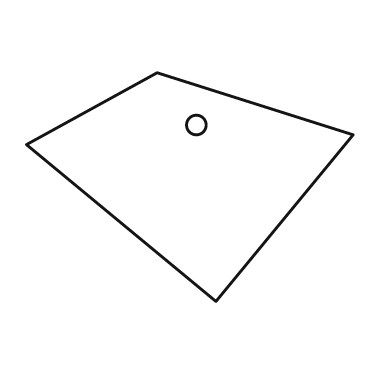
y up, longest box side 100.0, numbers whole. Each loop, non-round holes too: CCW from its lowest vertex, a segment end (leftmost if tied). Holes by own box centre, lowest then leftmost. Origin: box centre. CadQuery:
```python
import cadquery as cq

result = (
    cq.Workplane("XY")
    .moveTo(8.0, -35.0)
    .lineTo(50.0, 16.0)
    .lineTo(-10.0, 35.0)
    .lineTo(-50.0, 13.0)
    .close()
    .moveTo(2.0, 19.0)
    .circle(3.0)
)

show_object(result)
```